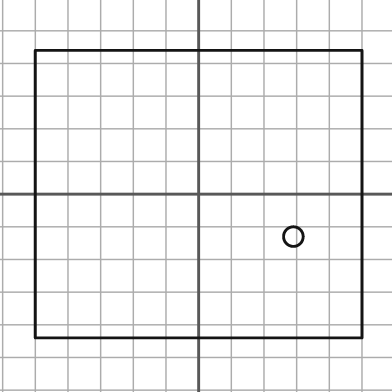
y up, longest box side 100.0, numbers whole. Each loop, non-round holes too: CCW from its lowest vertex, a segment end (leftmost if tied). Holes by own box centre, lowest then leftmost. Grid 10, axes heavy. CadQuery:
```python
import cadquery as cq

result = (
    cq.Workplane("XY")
    .moveTo(-50.0, -44.0)
    .lineTo(50.0, -44.0)
    .lineTo(50.0, 44.0)
    .lineTo(-50.0, 44.0)
    .close()
    .moveTo(29.0, -13.0)
    .circle(3.0)
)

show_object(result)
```